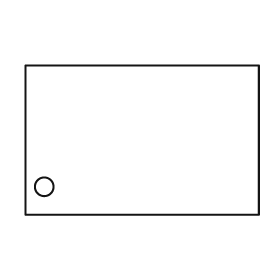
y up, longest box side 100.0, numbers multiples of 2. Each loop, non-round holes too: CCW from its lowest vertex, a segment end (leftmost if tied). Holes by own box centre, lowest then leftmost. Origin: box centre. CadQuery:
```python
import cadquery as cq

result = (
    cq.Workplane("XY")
    .moveTo(-50.0, -32.0)
    .lineTo(50.0, -32.0)
    .lineTo(50.0, 32.0)
    .lineTo(-50.0, 32.0)
    .close()
    .moveTo(-42.0, -20.0)
    .circle(4.0)
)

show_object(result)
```